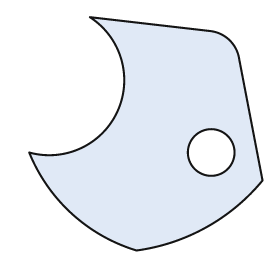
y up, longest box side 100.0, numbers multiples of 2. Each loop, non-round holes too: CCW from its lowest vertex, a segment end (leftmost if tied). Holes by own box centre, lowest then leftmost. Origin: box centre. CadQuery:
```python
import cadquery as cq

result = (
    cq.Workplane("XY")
    .moveTo(-4.0, -50.0)
    .threePointArc((26.0, -40.0), (50.0, -20.0))
    .lineTo(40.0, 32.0)
    .threePointArc((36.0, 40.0), (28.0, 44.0))
    .lineTo(-24.0, 50.0)
    .threePointArc((-12.0, 10.0), (-50.0, -8.0))
    .threePointArc((-32.0, -34.0), (-4.0, -50.0))
    .close()
    .moveTo(28.0, -8.0)
    .circle(10.0)
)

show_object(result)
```